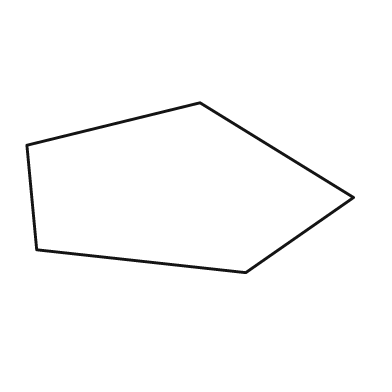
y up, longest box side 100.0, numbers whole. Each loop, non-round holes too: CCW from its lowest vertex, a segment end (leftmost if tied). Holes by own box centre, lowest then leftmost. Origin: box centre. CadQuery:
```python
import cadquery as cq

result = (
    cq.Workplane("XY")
    .moveTo(17.0, -26.0)
    .lineTo(50.0, -3.0)
    .lineTo(3.0, 26.0)
    .lineTo(-50.0, 13.0)
    .lineTo(-47.0, -19.0)
    .close()
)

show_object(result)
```